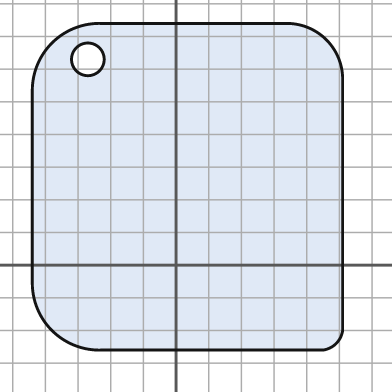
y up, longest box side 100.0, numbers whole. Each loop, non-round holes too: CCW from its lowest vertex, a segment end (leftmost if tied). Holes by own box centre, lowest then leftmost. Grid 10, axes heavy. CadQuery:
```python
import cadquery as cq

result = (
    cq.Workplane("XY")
    .moveTo(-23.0, -26.0)
    .lineTo(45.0, -26.0)
    .threePointArc((49.0, -24.0), (51.0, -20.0))
    .lineTo(51.0, 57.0)
    .threePointArc((46.0, 69.0), (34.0, 74.0))
    .lineTo(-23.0, 74.0)
    .threePointArc((-38.0, 68.0), (-44.0, 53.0))
    .lineTo(-44.0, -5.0)
    .threePointArc((-38.0, -20.0), (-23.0, -26.0))
    .close()
    .moveTo(-27.0, 63.0)
    .circle(5.0)
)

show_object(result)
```